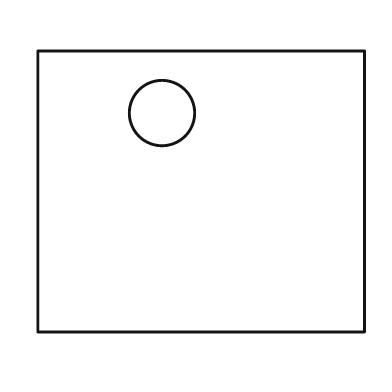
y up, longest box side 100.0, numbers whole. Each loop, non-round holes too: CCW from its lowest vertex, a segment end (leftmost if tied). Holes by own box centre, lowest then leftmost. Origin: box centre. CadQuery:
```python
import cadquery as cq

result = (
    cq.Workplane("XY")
    .moveTo(-50.0, -43.0)
    .lineTo(50.0, -43.0)
    .lineTo(50.0, 43.0)
    .lineTo(-50.0, 43.0)
    .close()
    .moveTo(-12.0, 24.0)
    .circle(10.0)
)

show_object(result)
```